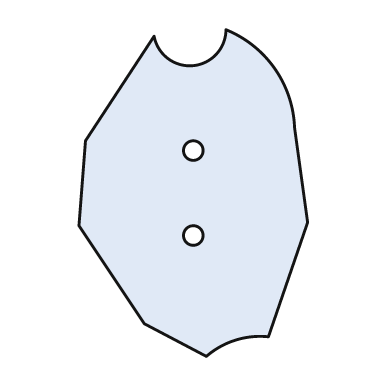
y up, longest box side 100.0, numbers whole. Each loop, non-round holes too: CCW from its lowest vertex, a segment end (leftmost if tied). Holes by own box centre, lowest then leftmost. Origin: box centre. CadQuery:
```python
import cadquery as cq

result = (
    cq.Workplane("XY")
    .moveTo(4.0, -50.0)
    .threePointArc((13.0, -45.0), (23.0, -44.0))
    .lineTo(35.0, -9.0)
    .lineTo(31.0, 20.0)
    .threePointArc((25.0, 38.0), (10.0, 50.0))
    .threePointArc((0.0, 39.0), (-12.0, 48.0))
    .lineTo(-33.0, 16.0)
    .lineTo(-35.0, -10.0)
    .lineTo(-15.0, -40.0)
    .close()
    .moveTo(0.0, -13.0)
    .circle(3.0)
    .moveTo(0.0, 13.0)
    .circle(3.0)
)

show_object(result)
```